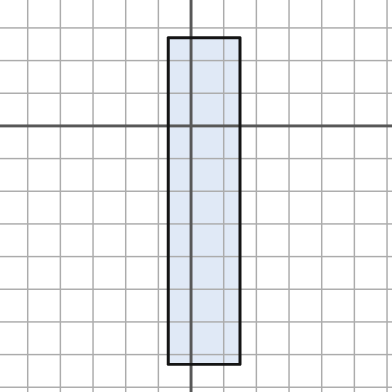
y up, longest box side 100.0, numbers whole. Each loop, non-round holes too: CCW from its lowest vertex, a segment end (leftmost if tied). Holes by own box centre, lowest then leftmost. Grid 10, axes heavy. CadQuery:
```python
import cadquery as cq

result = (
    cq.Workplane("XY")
    .moveTo(-7.0, -73.0)
    .lineTo(15.0, -73.0)
    .lineTo(15.0, 27.0)
    .lineTo(-7.0, 27.0)
    .close()
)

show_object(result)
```